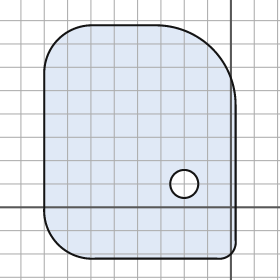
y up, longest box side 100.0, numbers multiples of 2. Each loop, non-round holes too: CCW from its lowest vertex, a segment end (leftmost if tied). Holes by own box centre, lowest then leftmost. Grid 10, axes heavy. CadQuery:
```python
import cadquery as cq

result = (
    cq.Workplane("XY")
    .moveTo(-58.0, -22.0)
    .lineTo(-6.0, -22.0)
    .threePointArc((0.0, -20.0), (2.0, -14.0))
    .lineTo(2.0, 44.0)
    .threePointArc((-8.0, 68.0), (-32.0, 78.0))
    .lineTo(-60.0, 78.0)
    .threePointArc((-74.0, 72.0), (-80.0, 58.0))
    .lineTo(-80.0, 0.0)
    .threePointArc((-74.0, -16.0), (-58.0, -22.0))
    .close()
    .moveTo(-20.0, 10.0)
    .circle(6.0)
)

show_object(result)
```